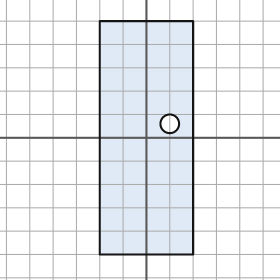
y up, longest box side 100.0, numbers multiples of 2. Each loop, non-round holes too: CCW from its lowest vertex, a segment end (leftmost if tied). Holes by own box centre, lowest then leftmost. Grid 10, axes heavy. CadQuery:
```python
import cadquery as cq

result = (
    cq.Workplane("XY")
    .moveTo(-20.0, -50.0)
    .lineTo(20.0, -50.0)
    .lineTo(20.0, 50.0)
    .lineTo(-20.0, 50.0)
    .close()
    .moveTo(10.0, 6.0)
    .circle(4.0)
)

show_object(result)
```